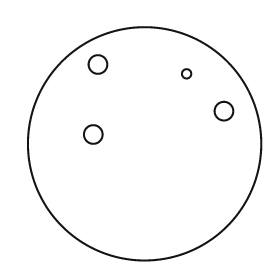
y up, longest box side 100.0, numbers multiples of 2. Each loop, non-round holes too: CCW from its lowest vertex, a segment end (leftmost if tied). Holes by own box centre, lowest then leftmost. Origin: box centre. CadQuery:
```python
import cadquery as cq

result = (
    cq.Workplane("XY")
    .moveTo(0.0, 0.0)
    .circle(50.0)
    .moveTo(-22.0, 4.0)
    .circle(4.0)
    .moveTo(34.0, 14.0)
    .circle(4.0)
    .moveTo(18.0, 30.0)
    .circle(2.0)
    .moveTo(-20.0, 34.0)
    .circle(4.0)
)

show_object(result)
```